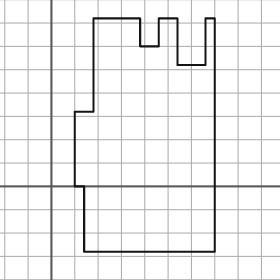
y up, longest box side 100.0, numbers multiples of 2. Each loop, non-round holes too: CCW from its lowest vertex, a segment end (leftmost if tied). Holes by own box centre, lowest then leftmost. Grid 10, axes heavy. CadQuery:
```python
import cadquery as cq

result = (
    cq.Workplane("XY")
    .moveTo(14.0, -28.0)
    .lineTo(70.0, -28.0)
    .lineTo(70.0, 72.0)
    .lineTo(66.0, 72.0)
    .lineTo(66.0, 52.0)
    .lineTo(54.0, 52.0)
    .lineTo(54.0, 72.0)
    .lineTo(46.0, 72.0)
    .lineTo(46.0, 60.0)
    .lineTo(38.0, 60.0)
    .lineTo(38.0, 72.0)
    .lineTo(18.0, 72.0)
    .lineTo(18.0, 32.0)
    .lineTo(10.0, 32.0)
    .lineTo(10.0, 0.0)
    .lineTo(14.0, 0.0)
    .close()
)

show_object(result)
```